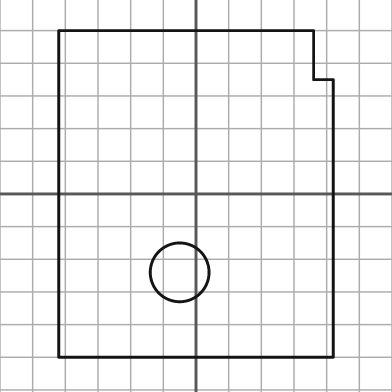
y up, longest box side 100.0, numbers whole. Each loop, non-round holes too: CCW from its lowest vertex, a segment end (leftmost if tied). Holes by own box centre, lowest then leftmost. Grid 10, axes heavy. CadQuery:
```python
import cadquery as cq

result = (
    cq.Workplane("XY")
    .moveTo(-42.0, -50.0)
    .lineTo(42.0, -50.0)
    .lineTo(42.0, 35.0)
    .lineTo(36.0, 35.0)
    .lineTo(36.0, 50.0)
    .lineTo(-42.0, 50.0)
    .close()
    .moveTo(-5.0, -24.0)
    .circle(9.0)
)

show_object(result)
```